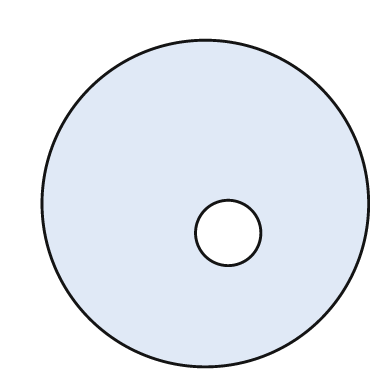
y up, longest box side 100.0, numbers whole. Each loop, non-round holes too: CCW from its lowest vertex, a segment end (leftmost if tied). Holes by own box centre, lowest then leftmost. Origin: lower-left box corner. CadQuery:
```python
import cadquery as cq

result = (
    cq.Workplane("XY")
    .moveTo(50.0, 50.0)
    .circle(50.0)
    .moveTo(57.0, 41.0)
    .circle(10.0)
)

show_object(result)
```